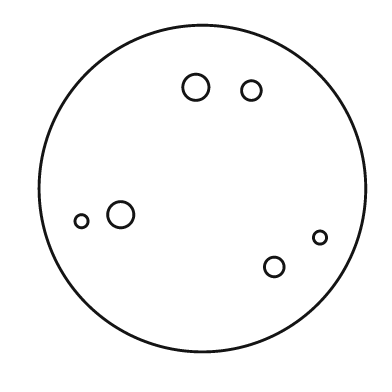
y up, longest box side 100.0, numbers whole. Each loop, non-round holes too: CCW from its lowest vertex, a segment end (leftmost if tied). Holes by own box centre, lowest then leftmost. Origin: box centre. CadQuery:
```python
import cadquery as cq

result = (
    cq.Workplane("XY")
    .moveTo(0.0, 0.0)
    .circle(50.0)
    .moveTo(22.0, -24.0)
    .circle(3.0)
    .moveTo(36.0, -15.0)
    .circle(2.0)
    .moveTo(-37.0, -10.0)
    .circle(2.0)
    .moveTo(-25.0, -8.0)
    .circle(4.0)
    .moveTo(15.0, 30.0)
    .circle(3.0)
    .moveTo(-2.0, 31.0)
    .circle(4.0)
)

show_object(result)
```